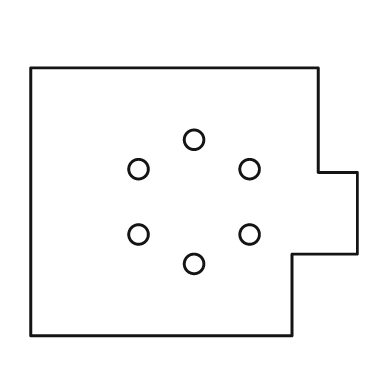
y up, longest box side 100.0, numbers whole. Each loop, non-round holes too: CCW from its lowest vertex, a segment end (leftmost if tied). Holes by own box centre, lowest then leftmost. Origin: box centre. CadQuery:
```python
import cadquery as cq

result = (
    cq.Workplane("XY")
    .moveTo(-50.0, -41.0)
    .lineTo(30.0, -41.0)
    .lineTo(30.0, -16.0)
    .lineTo(50.0, -16.0)
    .lineTo(50.0, 9.0)
    .lineTo(38.0, 9.0)
    .lineTo(38.0, 41.0)
    .lineTo(-50.0, 41.0)
    .close()
    .moveTo(0.0, -19.0)
    .circle(3.0)
    .moveTo(-17.0, -10.0)
    .circle(3.0)
    .moveTo(17.0, -10.0)
    .circle(3.0)
    .moveTo(-17.0, 10.0)
    .circle(3.0)
    .moveTo(17.0, 10.0)
    .circle(3.0)
    .moveTo(0.0, 19.0)
    .circle(3.0)
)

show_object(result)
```